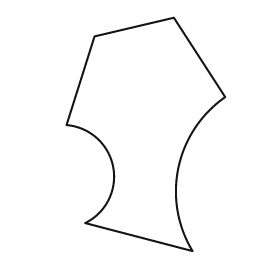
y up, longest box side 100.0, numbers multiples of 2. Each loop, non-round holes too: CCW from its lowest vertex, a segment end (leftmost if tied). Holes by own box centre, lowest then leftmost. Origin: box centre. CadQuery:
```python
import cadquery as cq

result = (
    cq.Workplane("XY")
    .moveTo(20.0, -50.0)
    .threePointArc((14.0, -14.0), (34.0, 16.0))
    .lineTo(12.0, 50.0)
    .lineTo(-22.0, 42.0)
    .lineTo(-34.0, 4.0)
    .threePointArc((-14.0, -14.0), (-26.0, -38.0))
    .close()
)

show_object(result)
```